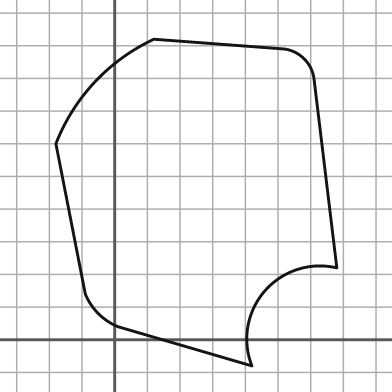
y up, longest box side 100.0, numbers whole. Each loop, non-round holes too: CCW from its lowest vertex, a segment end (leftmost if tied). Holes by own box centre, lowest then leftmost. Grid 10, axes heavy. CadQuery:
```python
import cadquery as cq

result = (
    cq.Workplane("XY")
    .moveTo(42.0, -8.0)
    .threePointArc((46.0, 15.0), (68.0, 22.0))
    .lineTo(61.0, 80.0)
    .threePointArc((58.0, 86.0), (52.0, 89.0))
    .lineTo(12.0, 92.0)
    .threePointArc((-6.0, 79.0), (-18.0, 60.0))
    .lineTo(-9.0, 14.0)
    .threePointArc((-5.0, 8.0), (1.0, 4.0))
    .close()
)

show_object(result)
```